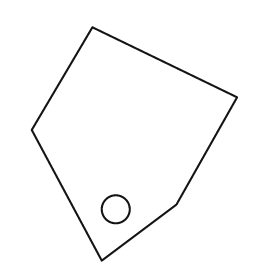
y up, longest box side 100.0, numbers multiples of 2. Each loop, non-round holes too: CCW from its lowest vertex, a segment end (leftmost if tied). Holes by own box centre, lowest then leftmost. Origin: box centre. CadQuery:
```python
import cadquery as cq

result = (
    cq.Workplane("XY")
    .moveTo(-14.0, -50.0)
    .lineTo(18.0, -26.0)
    .lineTo(44.0, 20.0)
    .lineTo(-18.0, 50.0)
    .lineTo(-44.0, 6.0)
    .close()
    .moveTo(-8.0, -28.0)
    .circle(6.0)
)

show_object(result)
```